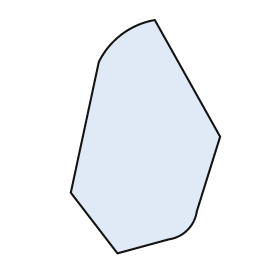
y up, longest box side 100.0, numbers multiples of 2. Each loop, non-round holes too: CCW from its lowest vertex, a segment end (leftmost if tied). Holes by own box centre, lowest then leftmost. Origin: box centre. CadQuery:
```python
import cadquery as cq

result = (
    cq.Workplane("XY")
    .moveTo(-12.0, -50.0)
    .lineTo(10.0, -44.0)
    .threePointArc((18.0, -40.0), (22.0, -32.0))
    .lineTo(32.0, 0.0)
    .lineTo(4.0, 50.0)
    .threePointArc((-10.0, 44.0), (-20.0, 32.0))
    .lineTo(-32.0, -24.0)
    .close()
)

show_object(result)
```